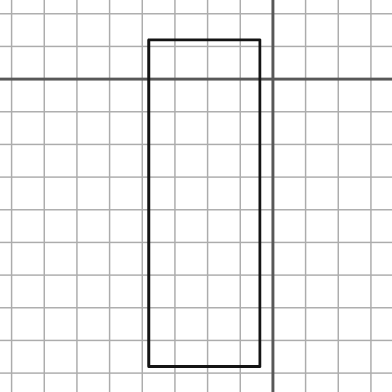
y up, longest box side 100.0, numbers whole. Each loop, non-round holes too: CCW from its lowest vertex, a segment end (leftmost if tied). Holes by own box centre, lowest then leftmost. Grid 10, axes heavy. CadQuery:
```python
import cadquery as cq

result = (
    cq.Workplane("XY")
    .moveTo(-38.0, -88.0)
    .lineTo(-4.0, -88.0)
    .lineTo(-4.0, 12.0)
    .lineTo(-38.0, 12.0)
    .close()
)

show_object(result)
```